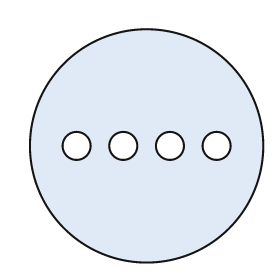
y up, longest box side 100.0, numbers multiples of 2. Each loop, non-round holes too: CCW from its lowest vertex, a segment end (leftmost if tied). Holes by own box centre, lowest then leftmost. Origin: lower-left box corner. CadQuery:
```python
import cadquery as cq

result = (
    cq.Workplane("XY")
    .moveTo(50.0, 50.0)
    .circle(50.0)
    .moveTo(20.0, 50.0)
    .circle(6.0)
    .moveTo(40.0, 50.0)
    .circle(6.0)
    .moveTo(60.0, 50.0)
    .circle(6.0)
    .moveTo(80.0, 50.0)
    .circle(6.0)
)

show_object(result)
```